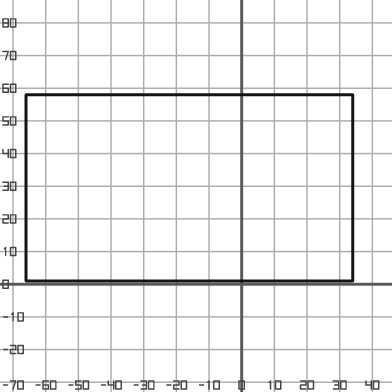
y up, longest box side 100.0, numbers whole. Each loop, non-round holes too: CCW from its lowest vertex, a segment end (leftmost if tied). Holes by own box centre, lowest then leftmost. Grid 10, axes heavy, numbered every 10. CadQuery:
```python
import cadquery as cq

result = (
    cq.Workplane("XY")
    .moveTo(-66.0, 1.0)
    .lineTo(34.0, 1.0)
    .lineTo(34.0, 58.0)
    .lineTo(-66.0, 58.0)
    .close()
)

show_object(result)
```